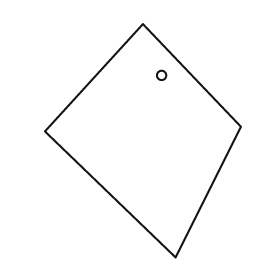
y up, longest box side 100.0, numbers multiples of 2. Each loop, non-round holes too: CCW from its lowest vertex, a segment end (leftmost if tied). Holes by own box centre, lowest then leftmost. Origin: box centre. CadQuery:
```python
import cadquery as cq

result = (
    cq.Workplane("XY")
    .moveTo(14.0, -50.0)
    .lineTo(42.0, 6.0)
    .lineTo(0.0, 50.0)
    .lineTo(-42.0, 4.0)
    .close()
    .moveTo(8.0, 28.0)
    .circle(2.0)
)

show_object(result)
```